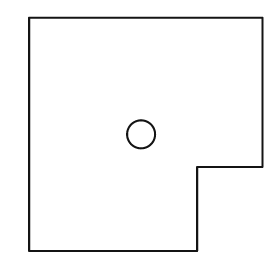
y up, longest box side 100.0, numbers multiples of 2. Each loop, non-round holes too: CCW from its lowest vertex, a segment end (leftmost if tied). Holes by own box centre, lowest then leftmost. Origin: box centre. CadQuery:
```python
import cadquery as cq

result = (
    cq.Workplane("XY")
    .moveTo(-50.0, -50.0)
    .lineTo(22.0, -50.0)
    .lineTo(22.0, -14.0)
    .lineTo(50.0, -14.0)
    .lineTo(50.0, 50.0)
    .lineTo(-50.0, 50.0)
    .close()
    .moveTo(-2.0, 0.0)
    .circle(6.0)
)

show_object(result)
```